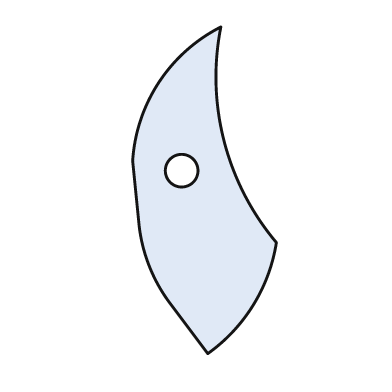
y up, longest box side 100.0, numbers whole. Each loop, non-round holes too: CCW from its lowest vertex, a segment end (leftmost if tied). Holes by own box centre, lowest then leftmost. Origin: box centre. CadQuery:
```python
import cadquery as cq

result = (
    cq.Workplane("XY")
    .moveTo(1.0, -50.0)
    .threePointArc((15.0, -35.0), (22.0, -16.0))
    .threePointArc((6.0, 15.0), (5.0, 50.0))
    .threePointArc((-14.0, 33.0), (-22.0, 9.0))
    .lineTo(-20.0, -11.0)
    .threePointArc((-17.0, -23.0), (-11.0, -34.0))
    .close()
    .moveTo(-7.0, 6.0)
    .circle(5.0)
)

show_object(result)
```